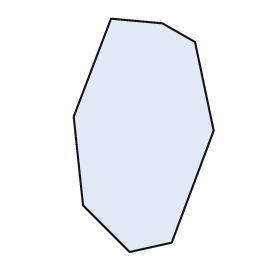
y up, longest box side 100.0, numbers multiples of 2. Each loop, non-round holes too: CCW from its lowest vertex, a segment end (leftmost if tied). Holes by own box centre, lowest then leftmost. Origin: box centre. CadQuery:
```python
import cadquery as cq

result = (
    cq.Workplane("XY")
    .moveTo(-6.0, -50.0)
    .lineTo(12.0, -46.0)
    .lineTo(30.0, 2.0)
    .lineTo(22.0, 40.0)
    .lineTo(8.0, 48.0)
    .lineTo(-14.0, 50.0)
    .lineTo(-30.0, 8.0)
    .lineTo(-26.0, -30.0)
    .close()
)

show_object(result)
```